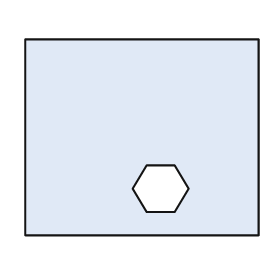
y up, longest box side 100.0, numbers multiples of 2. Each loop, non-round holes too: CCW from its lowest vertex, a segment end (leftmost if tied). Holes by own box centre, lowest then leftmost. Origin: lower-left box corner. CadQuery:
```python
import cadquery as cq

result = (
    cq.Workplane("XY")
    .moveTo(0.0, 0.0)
    .lineTo(100.0, 0.0)
    .lineTo(100.0, 84.0)
    .lineTo(0.0, 84.0)
    .close()
    .moveTo(52.0, 10.0)
    .lineTo(64.0, 10.0)
    .lineTo(70.0, 20.0)
    .lineTo(64.0, 30.0)
    .lineTo(52.0, 30.0)
    .lineTo(46.0, 20.0)
    .close()
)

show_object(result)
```